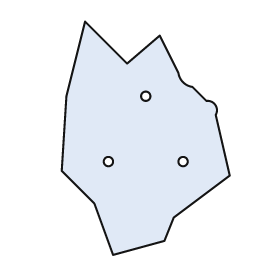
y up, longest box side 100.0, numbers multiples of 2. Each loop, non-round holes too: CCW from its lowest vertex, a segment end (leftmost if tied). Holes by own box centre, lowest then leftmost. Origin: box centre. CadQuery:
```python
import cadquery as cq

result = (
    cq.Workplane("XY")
    .moveTo(-14.0, -50.0)
    .lineTo(8.0, -44.0)
    .lineTo(12.0, -34.0)
    .lineTo(36.0, -16.0)
    .lineTo(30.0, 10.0)
    .threePointArc((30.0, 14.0), (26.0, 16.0))
    .lineTo(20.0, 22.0)
    .threePointArc((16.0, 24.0), (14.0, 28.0))
    .lineTo(6.0, 44.0)
    .lineTo(-8.0, 32.0)
    .lineTo(-26.0, 50.0)
    .lineTo(-34.0, 18.0)
    .lineTo(-36.0, -14.0)
    .lineTo(-22.0, -28.0)
    .close()
    .moveTo(-16.0, -10.0)
    .circle(2.0)
    .moveTo(16.0, -10.0)
    .circle(2.0)
    .moveTo(0.0, 18.0)
    .circle(2.0)
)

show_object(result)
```